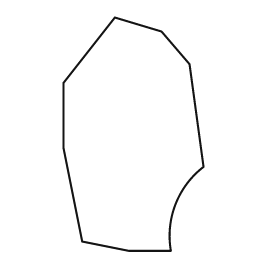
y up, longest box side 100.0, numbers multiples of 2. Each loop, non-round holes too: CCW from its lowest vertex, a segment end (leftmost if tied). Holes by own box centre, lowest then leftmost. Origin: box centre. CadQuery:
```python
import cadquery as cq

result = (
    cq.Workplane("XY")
    .moveTo(-2.0, -50.0)
    .lineTo(16.0, -50.0)
    .threePointArc((18.0, -30.0), (30.0, -14.0))
    .lineTo(24.0, 30.0)
    .lineTo(12.0, 44.0)
    .lineTo(-8.0, 50.0)
    .lineTo(-30.0, 22.0)
    .lineTo(-30.0, -6.0)
    .lineTo(-22.0, -46.0)
    .close()
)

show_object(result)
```